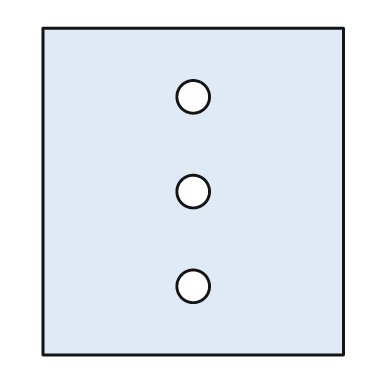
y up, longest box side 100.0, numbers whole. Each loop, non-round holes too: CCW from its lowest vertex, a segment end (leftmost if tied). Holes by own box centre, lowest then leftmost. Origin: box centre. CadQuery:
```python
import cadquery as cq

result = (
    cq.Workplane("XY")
    .moveTo(-46.0, -50.0)
    .lineTo(46.0, -50.0)
    .lineTo(46.0, 50.0)
    .lineTo(-46.0, 50.0)
    .close()
    .moveTo(0.0, -29.0)
    .circle(5.0)
    .moveTo(0.0, 0.0)
    .circle(5.0)
    .moveTo(0.0, 29.0)
    .circle(5.0)
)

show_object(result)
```